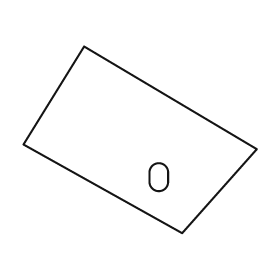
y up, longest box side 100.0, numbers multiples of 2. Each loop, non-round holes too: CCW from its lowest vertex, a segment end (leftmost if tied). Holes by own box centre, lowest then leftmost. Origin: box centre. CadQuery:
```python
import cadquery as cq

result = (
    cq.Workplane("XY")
    .moveTo(18.0, -40.0)
    .lineTo(50.0, -4.0)
    .lineTo(-24.0, 40.0)
    .lineTo(-50.0, -2.0)
    .close()
    .moveTo(4.0, -18.0)
    .threePointArc((8.0, -22.0), (12.0, -18.0))
    .lineTo(12.0, -14.0)
    .threePointArc((8.0, -10.0), (4.0, -14.0))
    .close()
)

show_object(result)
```